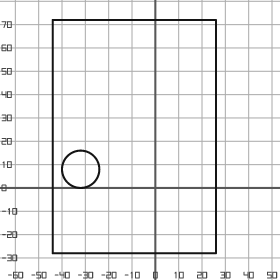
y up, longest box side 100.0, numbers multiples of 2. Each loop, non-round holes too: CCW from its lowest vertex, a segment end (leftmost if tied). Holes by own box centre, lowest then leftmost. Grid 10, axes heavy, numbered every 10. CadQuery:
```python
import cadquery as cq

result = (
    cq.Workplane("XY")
    .moveTo(-44.0, -28.0)
    .lineTo(26.0, -28.0)
    .lineTo(26.0, 72.0)
    .lineTo(-44.0, 72.0)
    .close()
    .moveTo(-32.0, 8.0)
    .circle(8.0)
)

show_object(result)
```